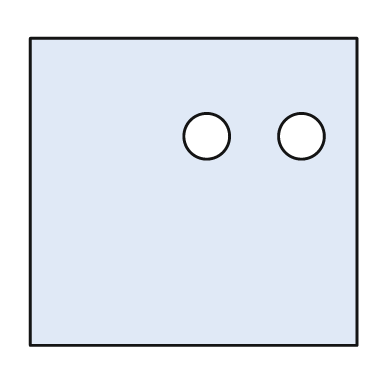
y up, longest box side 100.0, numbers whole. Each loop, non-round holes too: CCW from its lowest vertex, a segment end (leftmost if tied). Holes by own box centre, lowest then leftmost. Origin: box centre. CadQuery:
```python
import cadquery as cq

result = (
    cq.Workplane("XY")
    .moveTo(-50.0, -47.0)
    .lineTo(50.0, -47.0)
    .lineTo(50.0, 47.0)
    .lineTo(-50.0, 47.0)
    .close()
    .moveTo(4.0, 17.0)
    .circle(7.0)
    .moveTo(33.0, 17.0)
    .circle(7.0)
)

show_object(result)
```